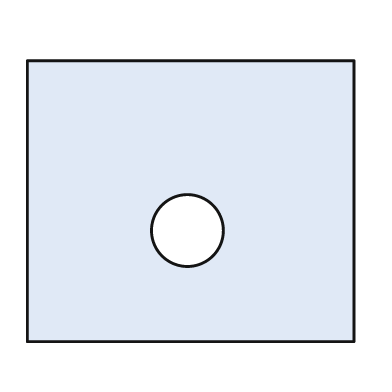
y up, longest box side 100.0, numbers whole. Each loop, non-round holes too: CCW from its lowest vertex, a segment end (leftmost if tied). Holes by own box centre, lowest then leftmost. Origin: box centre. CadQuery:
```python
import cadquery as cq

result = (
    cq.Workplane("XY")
    .moveTo(-50.0, -43.0)
    .lineTo(50.0, -43.0)
    .lineTo(50.0, 43.0)
    .lineTo(-50.0, 43.0)
    .close()
    .moveTo(-1.0, -9.0)
    .circle(11.0)
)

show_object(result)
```